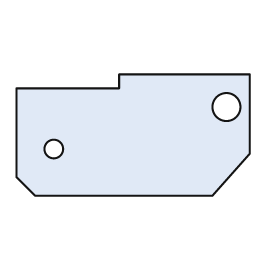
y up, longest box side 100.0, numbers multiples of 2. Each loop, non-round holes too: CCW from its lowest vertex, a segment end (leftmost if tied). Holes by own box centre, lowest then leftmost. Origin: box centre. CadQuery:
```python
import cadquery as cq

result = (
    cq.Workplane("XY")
    .moveTo(-42.0, -26.0)
    .lineTo(34.0, -26.0)
    .lineTo(50.0, -8.0)
    .lineTo(50.0, 26.0)
    .lineTo(-6.0, 26.0)
    .lineTo(-6.0, 20.0)
    .lineTo(-50.0, 20.0)
    .lineTo(-50.0, -18.0)
    .close()
    .moveTo(-34.0, -6.0)
    .circle(4.0)
    .moveTo(40.0, 12.0)
    .circle(6.0)
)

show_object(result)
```